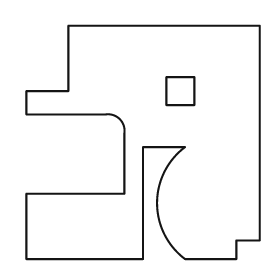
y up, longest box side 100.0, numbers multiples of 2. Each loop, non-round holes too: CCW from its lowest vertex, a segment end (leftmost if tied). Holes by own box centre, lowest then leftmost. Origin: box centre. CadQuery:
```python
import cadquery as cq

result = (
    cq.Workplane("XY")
    .moveTo(-50.0, -50.0)
    .lineTo(0.0, -50.0)
    .lineTo(0.0, -2.0)
    .lineTo(18.0, -2.0)
    .threePointArc((6.0, -26.0), (18.0, -50.0))
    .lineTo(40.0, -50.0)
    .lineTo(40.0, -42.0)
    .lineTo(50.0, -42.0)
    .lineTo(50.0, 50.0)
    .lineTo(-32.0, 50.0)
    .lineTo(-32.0, 22.0)
    .lineTo(-50.0, 22.0)
    .lineTo(-50.0, 12.0)
    .lineTo(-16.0, 12.0)
    .threePointArc((-10.0, 10.0), (-8.0, 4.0))
    .lineTo(-8.0, -22.0)
    .lineTo(-50.0, -22.0)
    .close()
    .moveTo(10.0, 16.0)
    .lineTo(22.0, 16.0)
    .lineTo(22.0, 28.0)
    .lineTo(10.0, 28.0)
    .close()
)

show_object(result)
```